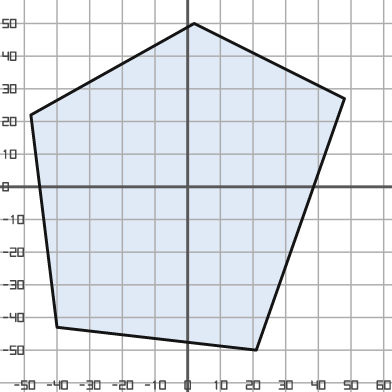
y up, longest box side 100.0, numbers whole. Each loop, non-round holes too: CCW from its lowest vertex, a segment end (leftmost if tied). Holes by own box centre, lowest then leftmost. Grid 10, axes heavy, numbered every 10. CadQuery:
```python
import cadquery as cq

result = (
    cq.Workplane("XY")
    .moveTo(21.0, -50.0)
    .lineTo(48.0, 27.0)
    .lineTo(2.0, 50.0)
    .lineTo(-48.0, 22.0)
    .lineTo(-40.0, -43.0)
    .close()
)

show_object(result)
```